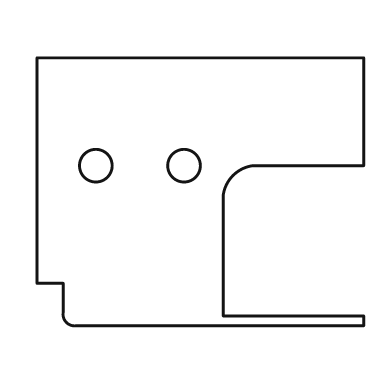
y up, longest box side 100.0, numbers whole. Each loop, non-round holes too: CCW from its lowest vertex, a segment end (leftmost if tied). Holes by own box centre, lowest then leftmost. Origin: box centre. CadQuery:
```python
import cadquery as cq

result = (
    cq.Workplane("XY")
    .moveTo(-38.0, -41.0)
    .lineTo(50.0, -41.0)
    .lineTo(50.0, -38.0)
    .lineTo(7.0, -38.0)
    .lineTo(7.0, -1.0)
    .threePointArc((10.0, 5.0), (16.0, 8.0))
    .lineTo(50.0, 8.0)
    .lineTo(50.0, 41.0)
    .lineTo(-50.0, 41.0)
    .lineTo(-50.0, -28.0)
    .lineTo(-42.0, -28.0)
    .lineTo(-42.0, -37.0)
    .threePointArc((-41.0, -40.0), (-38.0, -41.0))
    .close()
    .moveTo(-32.0, 8.0)
    .circle(5.0)
    .moveTo(-5.0, 8.0)
    .circle(5.0)
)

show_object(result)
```